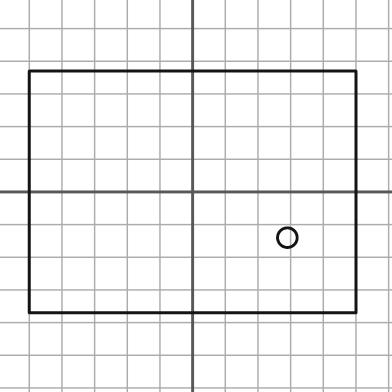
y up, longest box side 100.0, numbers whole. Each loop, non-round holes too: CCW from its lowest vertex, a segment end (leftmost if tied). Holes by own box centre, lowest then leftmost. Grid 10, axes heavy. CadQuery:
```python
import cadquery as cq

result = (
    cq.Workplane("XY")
    .moveTo(-50.0, -37.0)
    .lineTo(50.0, -37.0)
    .lineTo(50.0, 37.0)
    .lineTo(-50.0, 37.0)
    .close()
    .moveTo(29.0, -14.0)
    .circle(3.0)
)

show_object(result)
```